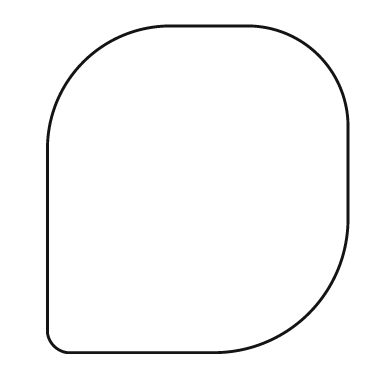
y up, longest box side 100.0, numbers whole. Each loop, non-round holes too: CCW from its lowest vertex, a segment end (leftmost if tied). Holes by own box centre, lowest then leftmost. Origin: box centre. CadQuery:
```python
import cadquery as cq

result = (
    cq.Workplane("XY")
    .moveTo(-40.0, -50.0)
    .lineTo(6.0, -50.0)
    .threePointArc((34.0, -38.0), (46.0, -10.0))
    .lineTo(46.0, 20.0)
    .threePointArc((37.0, 41.0), (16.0, 50.0))
    .lineTo(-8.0, 50.0)
    .threePointArc((-35.0, 39.0), (-46.0, 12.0))
    .lineTo(-46.0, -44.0)
    .threePointArc((-44.0, -48.0), (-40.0, -50.0))
    .close()
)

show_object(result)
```